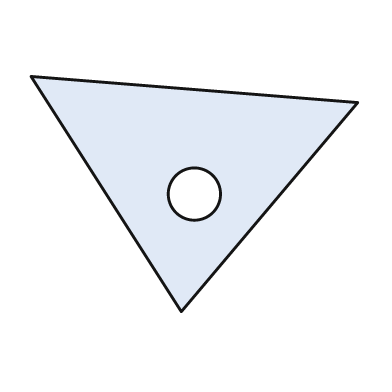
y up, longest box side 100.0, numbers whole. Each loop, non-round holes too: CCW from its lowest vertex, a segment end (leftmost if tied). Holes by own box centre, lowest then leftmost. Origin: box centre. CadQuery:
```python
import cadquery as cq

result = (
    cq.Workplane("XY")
    .moveTo(-4.0, -36.0)
    .lineTo(50.0, 28.0)
    .lineTo(-50.0, 36.0)
    .close()
    .moveTo(0.0, 0.0)
    .circle(8.0)
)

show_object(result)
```